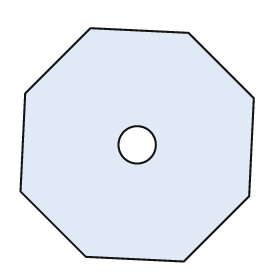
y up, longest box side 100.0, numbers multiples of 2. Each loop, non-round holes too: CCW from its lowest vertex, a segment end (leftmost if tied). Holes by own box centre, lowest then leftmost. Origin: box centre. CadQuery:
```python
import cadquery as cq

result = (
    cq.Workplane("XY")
    .moveTo(20.0, -50.0)
    .lineTo(48.0, -22.0)
    .lineTo(50.0, 20.0)
    .lineTo(22.0, 48.0)
    .lineTo(-20.0, 50.0)
    .lineTo(-48.0, 22.0)
    .lineTo(-50.0, -20.0)
    .lineTo(-22.0, -48.0)
    .close()
    .moveTo(0.0, 0.0)
    .circle(8.0)
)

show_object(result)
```